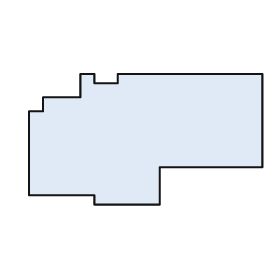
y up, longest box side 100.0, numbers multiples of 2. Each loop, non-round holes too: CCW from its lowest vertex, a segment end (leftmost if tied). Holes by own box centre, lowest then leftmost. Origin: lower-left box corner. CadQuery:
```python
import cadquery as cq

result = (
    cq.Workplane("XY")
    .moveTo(28.0, 0.0)
    .lineTo(56.0, 0.0)
    .lineTo(56.0, 16.0)
    .lineTo(100.0, 16.0)
    .lineTo(100.0, 56.0)
    .lineTo(38.0, 56.0)
    .lineTo(38.0, 52.0)
    .lineTo(28.0, 52.0)
    .lineTo(28.0, 56.0)
    .lineTo(22.0, 56.0)
    .lineTo(22.0, 46.0)
    .lineTo(6.0, 46.0)
    .lineTo(6.0, 40.0)
    .lineTo(0.0, 40.0)
    .lineTo(0.0, 4.0)
    .lineTo(28.0, 4.0)
    .close()
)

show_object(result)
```